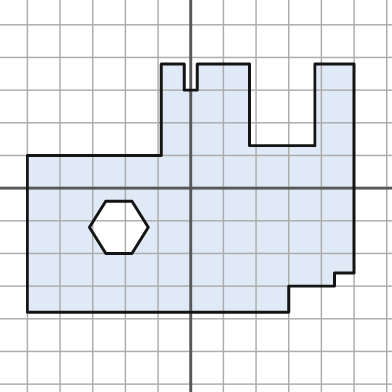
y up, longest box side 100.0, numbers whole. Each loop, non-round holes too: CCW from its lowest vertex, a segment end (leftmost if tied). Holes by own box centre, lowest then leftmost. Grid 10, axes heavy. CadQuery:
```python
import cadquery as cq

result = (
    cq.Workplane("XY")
    .moveTo(-50.0, -38.0)
    .lineTo(30.0, -38.0)
    .lineTo(30.0, -30.0)
    .lineTo(44.0, -30.0)
    .lineTo(44.0, -26.0)
    .lineTo(50.0, -26.0)
    .lineTo(50.0, 38.0)
    .lineTo(38.0, 38.0)
    .lineTo(38.0, 13.0)
    .lineTo(18.0, 13.0)
    .lineTo(18.0, 38.0)
    .lineTo(2.0, 38.0)
    .lineTo(2.0, 30.0)
    .lineTo(-2.0, 30.0)
    .lineTo(-2.0, 38.0)
    .lineTo(-9.0, 38.0)
    .lineTo(-9.0, 10.0)
    .lineTo(-50.0, 10.0)
    .close()
    .moveTo(-26.0, -20.0)
    .lineTo(-18.0, -20.0)
    .lineTo(-13.0, -12.0)
    .lineTo(-18.0, -4.0)
    .lineTo(-26.0, -4.0)
    .lineTo(-31.0, -12.0)
    .close()
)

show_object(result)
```